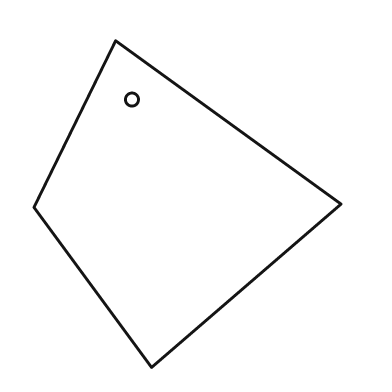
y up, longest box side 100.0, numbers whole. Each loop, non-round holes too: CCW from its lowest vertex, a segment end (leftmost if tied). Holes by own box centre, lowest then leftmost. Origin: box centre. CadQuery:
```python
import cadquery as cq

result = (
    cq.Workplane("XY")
    .moveTo(-11.0, -50.0)
    .lineTo(47.0, 0.0)
    .lineTo(-22.0, 50.0)
    .lineTo(-47.0, -1.0)
    .close()
    .moveTo(-17.0, 32.0)
    .circle(2.0)
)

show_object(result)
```